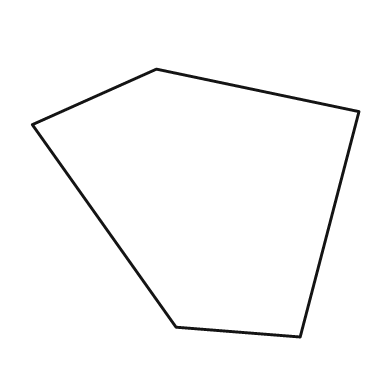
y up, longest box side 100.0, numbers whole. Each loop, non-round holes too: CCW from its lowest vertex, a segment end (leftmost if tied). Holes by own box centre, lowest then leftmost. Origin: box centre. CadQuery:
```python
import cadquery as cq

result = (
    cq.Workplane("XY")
    .moveTo(32.0, -41.0)
    .lineTo(50.0, 28.0)
    .lineTo(-12.0, 41.0)
    .lineTo(-50.0, 24.0)
    .lineTo(-6.0, -38.0)
    .close()
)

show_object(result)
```